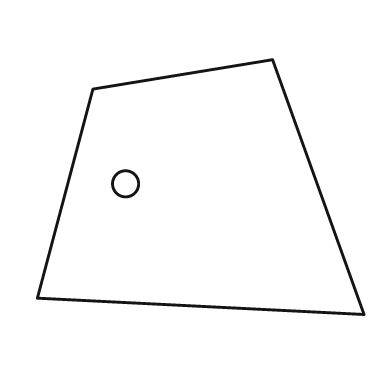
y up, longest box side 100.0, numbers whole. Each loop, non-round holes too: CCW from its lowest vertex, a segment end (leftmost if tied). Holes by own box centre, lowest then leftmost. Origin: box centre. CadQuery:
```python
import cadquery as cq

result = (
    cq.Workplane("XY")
    .moveTo(50.0, -39.0)
    .lineTo(22.0, 39.0)
    .lineTo(-33.0, 30.0)
    .lineTo(-50.0, -34.0)
    .close()
    .moveTo(-23.0, 1.0)
    .circle(4.0)
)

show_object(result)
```